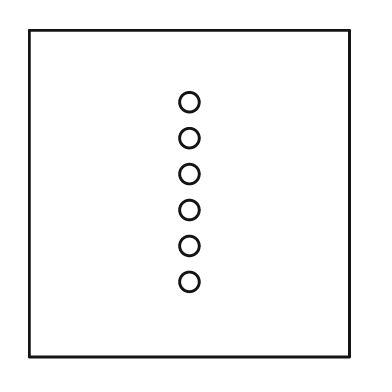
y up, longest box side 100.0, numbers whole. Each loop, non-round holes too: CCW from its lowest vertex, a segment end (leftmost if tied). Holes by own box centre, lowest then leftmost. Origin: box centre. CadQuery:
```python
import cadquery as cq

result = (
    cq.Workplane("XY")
    .moveTo(-49.0, -50.0)
    .lineTo(49.0, -50.0)
    .lineTo(49.0, 50.0)
    .lineTo(-49.0, 50.0)
    .close()
    .moveTo(0.0, -27.0)
    .circle(3.0)
    .moveTo(0.0, -16.0)
    .circle(3.0)
    .moveTo(0.0, -5.0)
    .circle(3.0)
    .moveTo(0.0, 6.0)
    .circle(3.0)
    .moveTo(0.0, 17.0)
    .circle(3.0)
    .moveTo(0.0, 28.0)
    .circle(3.0)
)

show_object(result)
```